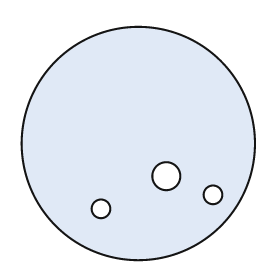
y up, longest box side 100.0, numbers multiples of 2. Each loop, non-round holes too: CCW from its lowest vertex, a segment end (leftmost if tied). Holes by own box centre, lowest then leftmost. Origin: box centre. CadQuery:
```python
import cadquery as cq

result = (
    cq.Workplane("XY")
    .moveTo(0.0, 0.0)
    .circle(50.0)
    .moveTo(-16.0, -28.0)
    .circle(4.0)
    .moveTo(32.0, -22.0)
    .circle(4.0)
    .moveTo(12.0, -14.0)
    .circle(6.0)
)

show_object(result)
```